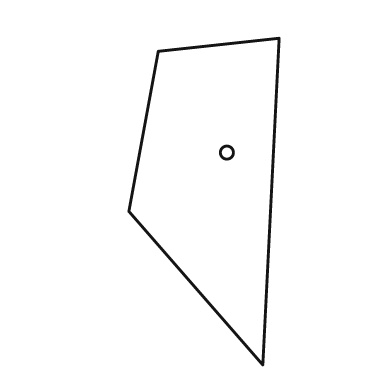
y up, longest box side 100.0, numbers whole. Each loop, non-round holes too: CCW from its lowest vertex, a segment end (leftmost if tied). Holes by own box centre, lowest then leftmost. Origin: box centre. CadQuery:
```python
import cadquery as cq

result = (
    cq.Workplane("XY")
    .moveTo(18.0, -50.0)
    .lineTo(23.0, 50.0)
    .lineTo(-14.0, 46.0)
    .lineTo(-23.0, -3.0)
    .close()
    .moveTo(7.0, 15.0)
    .circle(2.0)
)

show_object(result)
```